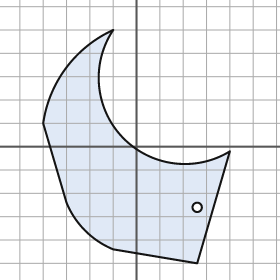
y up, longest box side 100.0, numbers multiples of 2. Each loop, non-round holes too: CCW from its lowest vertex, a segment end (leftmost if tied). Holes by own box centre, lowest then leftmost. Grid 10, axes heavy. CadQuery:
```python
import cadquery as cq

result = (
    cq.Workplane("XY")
    .moveTo(26.0, -50.0)
    .lineTo(40.0, -2.0)
    .threePointArc((-6.0, 4.0), (-10.0, 50.0))
    .threePointArc((-30.0, 34.0), (-40.0, 10.0))
    .lineTo(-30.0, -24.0)
    .threePointArc((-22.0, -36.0), (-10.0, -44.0))
    .close()
    .moveTo(26.0, -26.0)
    .circle(2.0)
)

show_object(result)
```